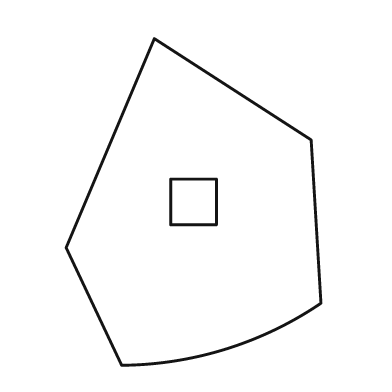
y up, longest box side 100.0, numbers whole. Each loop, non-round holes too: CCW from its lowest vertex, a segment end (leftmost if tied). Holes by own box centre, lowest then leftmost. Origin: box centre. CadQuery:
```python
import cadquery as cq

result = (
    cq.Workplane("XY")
    .moveTo(-22.0, -50.0)
    .threePointArc((10.0, -45.0), (39.0, -31.0))
    .lineTo(36.0, 19.0)
    .lineTo(-12.0, 50.0)
    .lineTo(-39.0, -14.0)
    .close()
    .moveTo(-7.0, -7.0)
    .lineTo(7.0, -7.0)
    .lineTo(7.0, 7.0)
    .lineTo(-7.0, 7.0)
    .close()
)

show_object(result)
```